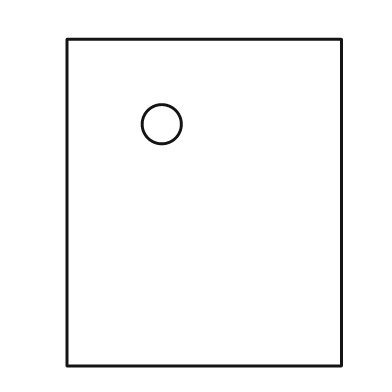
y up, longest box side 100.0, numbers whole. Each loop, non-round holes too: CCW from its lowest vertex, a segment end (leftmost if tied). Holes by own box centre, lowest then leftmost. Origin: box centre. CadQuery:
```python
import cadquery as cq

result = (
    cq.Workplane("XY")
    .moveTo(-42.0, -50.0)
    .lineTo(42.0, -50.0)
    .lineTo(42.0, 50.0)
    .lineTo(-42.0, 50.0)
    .close()
    .moveTo(-13.0, 24.0)
    .circle(6.0)
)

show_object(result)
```